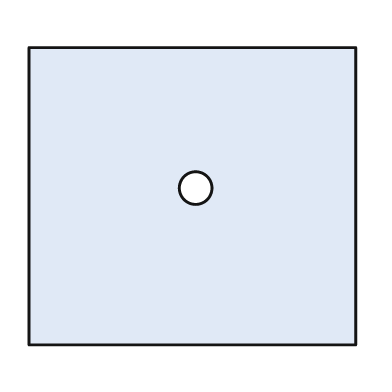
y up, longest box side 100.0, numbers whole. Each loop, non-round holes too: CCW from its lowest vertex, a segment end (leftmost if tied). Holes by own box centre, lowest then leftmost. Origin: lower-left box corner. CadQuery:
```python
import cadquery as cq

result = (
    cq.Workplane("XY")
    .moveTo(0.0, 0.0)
    .lineTo(100.0, 0.0)
    .lineTo(100.0, 91.0)
    .lineTo(0.0, 91.0)
    .close()
    .moveTo(51.0, 48.0)
    .circle(5.0)
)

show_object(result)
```